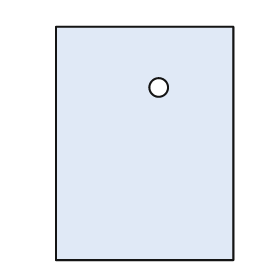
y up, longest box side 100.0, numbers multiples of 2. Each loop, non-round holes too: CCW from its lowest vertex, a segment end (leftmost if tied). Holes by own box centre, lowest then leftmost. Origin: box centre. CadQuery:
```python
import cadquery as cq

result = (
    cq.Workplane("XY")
    .moveTo(-38.0, -50.0)
    .lineTo(38.0, -50.0)
    .lineTo(38.0, 50.0)
    .lineTo(-38.0, 50.0)
    .close()
    .moveTo(6.0, 24.0)
    .circle(4.0)
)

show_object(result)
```